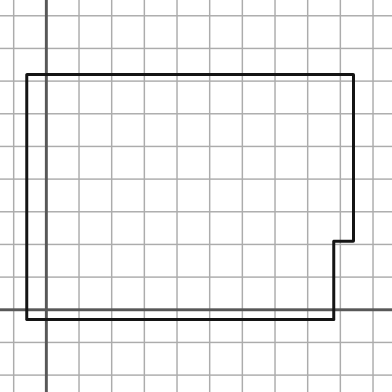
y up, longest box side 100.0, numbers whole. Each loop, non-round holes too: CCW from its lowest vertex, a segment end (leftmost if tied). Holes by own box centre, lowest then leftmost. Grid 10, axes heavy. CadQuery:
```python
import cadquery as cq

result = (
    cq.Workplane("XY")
    .moveTo(-6.0, -3.0)
    .lineTo(88.0, -3.0)
    .lineTo(88.0, 21.0)
    .lineTo(94.0, 21.0)
    .lineTo(94.0, 72.0)
    .lineTo(-6.0, 72.0)
    .close()
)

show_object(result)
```